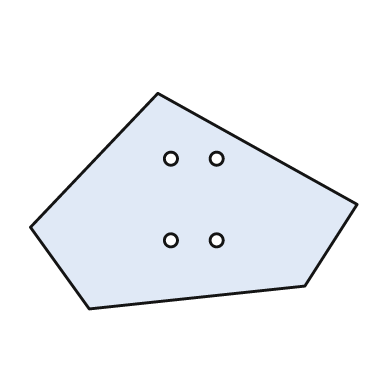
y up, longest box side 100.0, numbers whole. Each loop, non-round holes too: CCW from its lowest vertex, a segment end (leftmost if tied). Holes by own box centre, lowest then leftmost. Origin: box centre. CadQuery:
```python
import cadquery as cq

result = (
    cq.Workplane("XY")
    .moveTo(-32.0, -33.0)
    .lineTo(34.0, -26.0)
    .lineTo(50.0, -1.0)
    .lineTo(-11.0, 33.0)
    .lineTo(-50.0, -8.0)
    .close()
    .moveTo(-7.0, -12.0)
    .circle(2.0)
    .moveTo(7.0, -12.0)
    .circle(2.0)
    .moveTo(-7.0, 13.0)
    .circle(2.0)
    .moveTo(7.0, 13.0)
    .circle(2.0)
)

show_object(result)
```